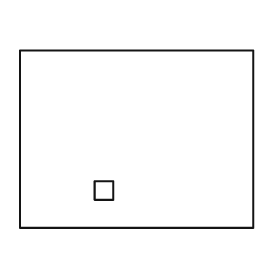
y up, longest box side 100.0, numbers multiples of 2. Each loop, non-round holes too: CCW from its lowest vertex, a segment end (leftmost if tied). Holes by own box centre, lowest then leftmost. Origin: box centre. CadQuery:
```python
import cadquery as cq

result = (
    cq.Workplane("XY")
    .moveTo(-50.0, -38.0)
    .lineTo(50.0, -38.0)
    .lineTo(50.0, 38.0)
    .lineTo(-50.0, 38.0)
    .close()
    .moveTo(-18.0, -26.0)
    .lineTo(-10.0, -26.0)
    .lineTo(-10.0, -18.0)
    .lineTo(-18.0, -18.0)
    .close()
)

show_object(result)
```